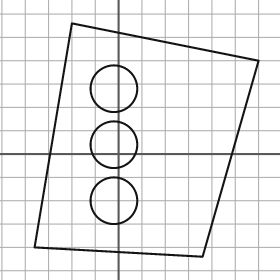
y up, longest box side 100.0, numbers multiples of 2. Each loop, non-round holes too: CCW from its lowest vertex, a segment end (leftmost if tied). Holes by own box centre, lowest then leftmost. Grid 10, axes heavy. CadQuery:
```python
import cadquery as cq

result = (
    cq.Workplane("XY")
    .moveTo(36.0, -44.0)
    .lineTo(60.0, 40.0)
    .lineTo(-20.0, 56.0)
    .lineTo(-36.0, -40.0)
    .close()
    .moveTo(-2.0, -20.0)
    .circle(10.0)
    .moveTo(-2.0, 4.0)
    .circle(10.0)
    .moveTo(-2.0, 28.0)
    .circle(10.0)
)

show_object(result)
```